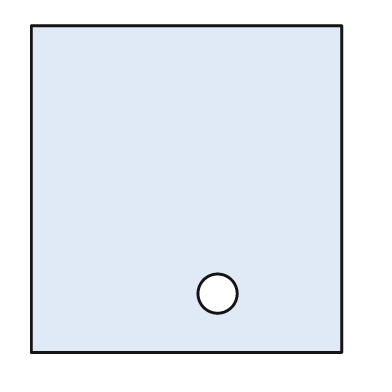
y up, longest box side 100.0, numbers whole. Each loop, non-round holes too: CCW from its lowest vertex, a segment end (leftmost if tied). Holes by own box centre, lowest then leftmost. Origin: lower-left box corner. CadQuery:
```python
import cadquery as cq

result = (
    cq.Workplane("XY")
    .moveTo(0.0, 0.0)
    .lineTo(95.0, 0.0)
    .lineTo(95.0, 100.0)
    .lineTo(0.0, 100.0)
    .close()
    .moveTo(57.0, 18.0)
    .circle(6.0)
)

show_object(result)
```